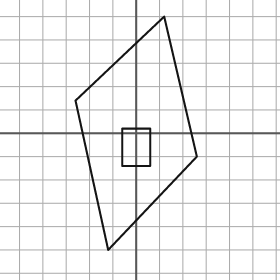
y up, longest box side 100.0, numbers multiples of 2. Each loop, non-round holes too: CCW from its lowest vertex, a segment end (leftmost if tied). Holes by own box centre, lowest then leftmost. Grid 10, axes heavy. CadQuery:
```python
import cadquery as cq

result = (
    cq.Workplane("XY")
    .moveTo(-12.0, -50.0)
    .lineTo(26.0, -10.0)
    .lineTo(12.0, 50.0)
    .lineTo(-26.0, 14.0)
    .close()
    .moveTo(-6.0, -14.0)
    .lineTo(6.0, -14.0)
    .lineTo(6.0, 2.0)
    .lineTo(-6.0, 2.0)
    .close()
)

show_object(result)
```